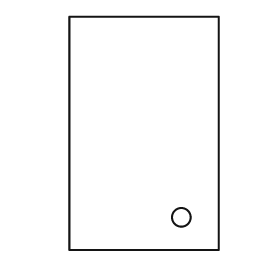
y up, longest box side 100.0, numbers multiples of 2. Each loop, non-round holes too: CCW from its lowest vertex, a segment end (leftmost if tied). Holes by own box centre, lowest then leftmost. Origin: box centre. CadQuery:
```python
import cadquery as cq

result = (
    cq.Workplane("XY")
    .moveTo(-32.0, -50.0)
    .lineTo(32.0, -50.0)
    .lineTo(32.0, 50.0)
    .lineTo(-32.0, 50.0)
    .close()
    .moveTo(16.0, -36.0)
    .circle(4.0)
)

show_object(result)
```